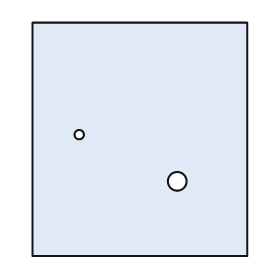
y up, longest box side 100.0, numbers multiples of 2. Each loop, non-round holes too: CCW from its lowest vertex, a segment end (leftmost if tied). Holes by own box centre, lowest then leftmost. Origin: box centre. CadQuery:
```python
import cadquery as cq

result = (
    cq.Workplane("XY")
    .moveTo(-46.0, -50.0)
    .lineTo(46.0, -50.0)
    .lineTo(46.0, 50.0)
    .lineTo(-46.0, 50.0)
    .close()
    .moveTo(16.0, -18.0)
    .circle(4.0)
    .moveTo(-26.0, 2.0)
    .circle(2.0)
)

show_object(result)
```